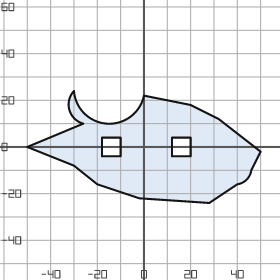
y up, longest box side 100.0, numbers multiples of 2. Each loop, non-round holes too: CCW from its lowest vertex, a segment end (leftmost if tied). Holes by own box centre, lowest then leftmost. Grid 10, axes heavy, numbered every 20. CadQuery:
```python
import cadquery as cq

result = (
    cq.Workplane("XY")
    .moveTo(28.0, -24.0)
    .lineTo(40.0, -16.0)
    .threePointArc((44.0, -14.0), (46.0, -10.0))
    .lineTo(50.0, -2.0)
    .lineTo(32.0, 12.0)
    .lineTo(20.0, 18.0)
    .lineTo(0.0, 22.0)
    .threePointArc((-16.0, 10.0), (-30.0, 24.0))
    .threePointArc((-32.0, 16.0), (-26.0, 10.0))
    .lineTo(-50.0, 0.0)
    .lineTo(-30.0, -8.0)
    .lineTo(-20.0, -16.0)
    .lineTo(-2.0, -22.0)
    .close()
    .moveTo(-18.0, -4.0)
    .lineTo(-10.0, -4.0)
    .lineTo(-10.0, 4.0)
    .lineTo(-18.0, 4.0)
    .close()
    .moveTo(12.0, -4.0)
    .lineTo(20.0, -4.0)
    .lineTo(20.0, 4.0)
    .lineTo(12.0, 4.0)
    .close()
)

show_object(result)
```